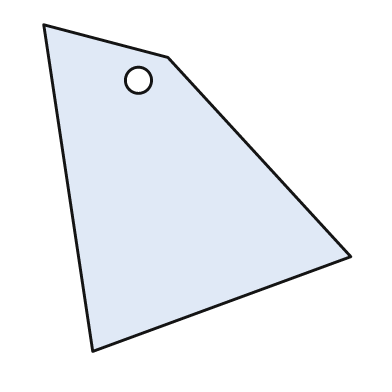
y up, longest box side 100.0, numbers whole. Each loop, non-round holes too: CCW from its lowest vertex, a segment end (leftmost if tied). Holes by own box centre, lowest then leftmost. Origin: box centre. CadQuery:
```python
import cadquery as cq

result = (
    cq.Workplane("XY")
    .moveTo(-32.0, -50.0)
    .lineTo(47.0, -21.0)
    .lineTo(-9.0, 40.0)
    .lineTo(-47.0, 50.0)
    .close()
    .moveTo(-18.0, 33.0)
    .circle(4.0)
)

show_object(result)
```